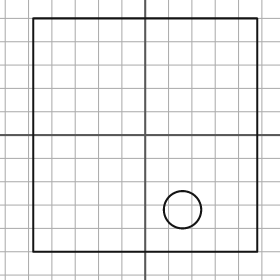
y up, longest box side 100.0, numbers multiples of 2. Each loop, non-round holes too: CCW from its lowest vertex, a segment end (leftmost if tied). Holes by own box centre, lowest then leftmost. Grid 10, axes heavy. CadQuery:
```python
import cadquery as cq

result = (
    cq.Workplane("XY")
    .moveTo(-48.0, -50.0)
    .lineTo(48.0, -50.0)
    .lineTo(48.0, 50.0)
    .lineTo(-48.0, 50.0)
    .close()
    .moveTo(16.0, -32.0)
    .circle(8.0)
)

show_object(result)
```